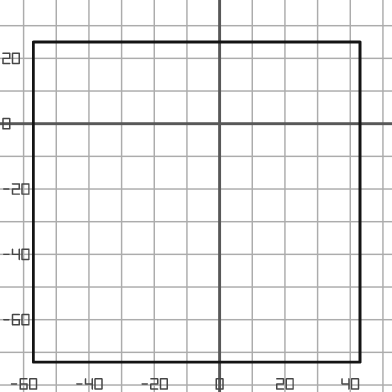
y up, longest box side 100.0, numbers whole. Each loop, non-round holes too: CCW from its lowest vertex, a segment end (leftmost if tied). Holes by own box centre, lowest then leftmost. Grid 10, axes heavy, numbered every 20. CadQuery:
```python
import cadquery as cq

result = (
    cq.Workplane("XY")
    .moveTo(-57.0, -73.0)
    .lineTo(43.0, -73.0)
    .lineTo(43.0, 25.0)
    .lineTo(-57.0, 25.0)
    .close()
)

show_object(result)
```